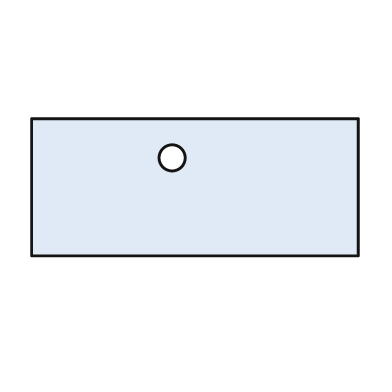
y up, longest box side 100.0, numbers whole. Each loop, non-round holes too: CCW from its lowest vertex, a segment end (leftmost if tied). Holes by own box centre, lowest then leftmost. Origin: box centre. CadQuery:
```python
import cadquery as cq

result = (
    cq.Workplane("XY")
    .moveTo(-50.0, -21.0)
    .lineTo(50.0, -21.0)
    .lineTo(50.0, 21.0)
    .lineTo(-50.0, 21.0)
    .close()
    .moveTo(-7.0, 9.0)
    .circle(4.0)
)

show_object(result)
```